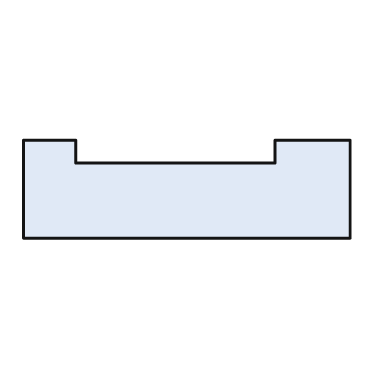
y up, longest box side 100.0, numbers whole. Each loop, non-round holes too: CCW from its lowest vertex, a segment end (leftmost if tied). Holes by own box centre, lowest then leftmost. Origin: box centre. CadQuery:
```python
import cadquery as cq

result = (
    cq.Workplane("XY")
    .moveTo(-50.0, -15.0)
    .lineTo(50.0, -15.0)
    .lineTo(50.0, 15.0)
    .lineTo(27.0, 15.0)
    .lineTo(27.0, 8.0)
    .lineTo(-34.0, 8.0)
    .lineTo(-34.0, 15.0)
    .lineTo(-50.0, 15.0)
    .close()
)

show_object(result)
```